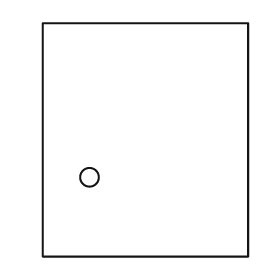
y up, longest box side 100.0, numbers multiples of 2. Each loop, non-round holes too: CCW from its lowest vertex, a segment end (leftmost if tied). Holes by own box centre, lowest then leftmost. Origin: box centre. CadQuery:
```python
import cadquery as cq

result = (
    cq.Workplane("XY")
    .moveTo(-44.0, -50.0)
    .lineTo(44.0, -50.0)
    .lineTo(44.0, 50.0)
    .lineTo(-44.0, 50.0)
    .close()
    .moveTo(-24.0, -16.0)
    .circle(4.0)
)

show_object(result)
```